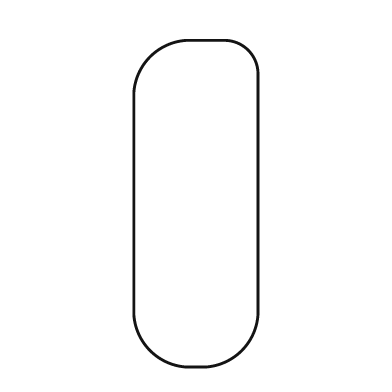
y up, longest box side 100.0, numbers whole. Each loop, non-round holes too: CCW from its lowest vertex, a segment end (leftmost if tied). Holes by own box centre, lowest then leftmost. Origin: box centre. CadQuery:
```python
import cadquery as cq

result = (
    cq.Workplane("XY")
    .moveTo(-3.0, -50.0)
    .lineTo(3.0, -50.0)
    .threePointArc((14.0, -45.0), (19.0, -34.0))
    .lineTo(19.0, 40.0)
    .threePointArc((16.0, 47.0), (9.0, 50.0))
    .lineTo(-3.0, 50.0)
    .threePointArc((-14.0, 45.0), (-19.0, 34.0))
    .lineTo(-19.0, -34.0)
    .threePointArc((-14.0, -45.0), (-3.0, -50.0))
    .close()
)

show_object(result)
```